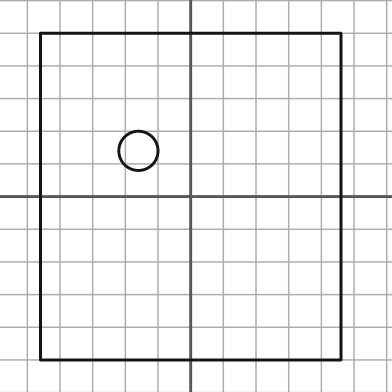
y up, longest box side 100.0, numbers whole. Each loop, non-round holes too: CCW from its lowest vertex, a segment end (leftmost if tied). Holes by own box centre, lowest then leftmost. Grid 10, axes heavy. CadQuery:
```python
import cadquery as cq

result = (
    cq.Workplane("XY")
    .moveTo(-46.0, -50.0)
    .lineTo(46.0, -50.0)
    .lineTo(46.0, 50.0)
    .lineTo(-46.0, 50.0)
    .close()
    .moveTo(-16.0, 14.0)
    .circle(6.0)
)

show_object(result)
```